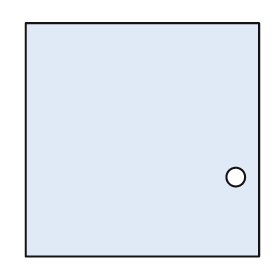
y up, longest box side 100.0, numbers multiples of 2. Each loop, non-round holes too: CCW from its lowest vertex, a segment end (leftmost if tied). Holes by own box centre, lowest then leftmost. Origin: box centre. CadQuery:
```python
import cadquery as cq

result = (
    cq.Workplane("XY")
    .moveTo(-50.0, -50.0)
    .lineTo(50.0, -50.0)
    .lineTo(50.0, 50.0)
    .lineTo(-50.0, 50.0)
    .close()
    .moveTo(40.0, -16.0)
    .circle(4.0)
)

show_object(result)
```